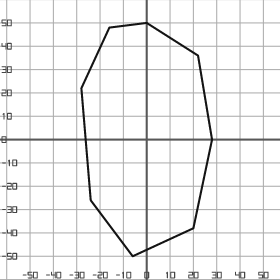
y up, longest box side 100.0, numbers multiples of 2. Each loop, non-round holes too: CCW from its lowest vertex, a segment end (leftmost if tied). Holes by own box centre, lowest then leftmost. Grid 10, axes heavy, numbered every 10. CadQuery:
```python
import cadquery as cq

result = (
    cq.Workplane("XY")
    .moveTo(-6.0, -50.0)
    .lineTo(20.0, -38.0)
    .lineTo(28.0, 0.0)
    .lineTo(22.0, 36.0)
    .lineTo(0.0, 50.0)
    .lineTo(-16.0, 48.0)
    .lineTo(-28.0, 22.0)
    .lineTo(-24.0, -26.0)
    .close()
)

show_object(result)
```